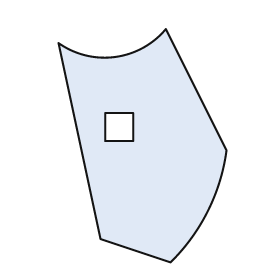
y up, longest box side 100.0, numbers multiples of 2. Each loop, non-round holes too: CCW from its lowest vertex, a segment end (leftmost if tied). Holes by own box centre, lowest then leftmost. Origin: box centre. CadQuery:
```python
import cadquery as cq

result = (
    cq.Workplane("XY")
    .moveTo(12.0, -50.0)
    .threePointArc((28.0, -28.0), (36.0, -2.0))
    .lineTo(10.0, 50.0)
    .threePointArc((-12.0, 38.0), (-36.0, 44.0))
    .lineTo(-18.0, -40.0)
    .close()
    .moveTo(-16.0, 2.0)
    .lineTo(-4.0, 2.0)
    .lineTo(-4.0, 14.0)
    .lineTo(-16.0, 14.0)
    .close()
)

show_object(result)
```